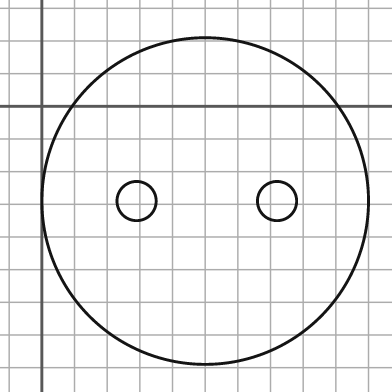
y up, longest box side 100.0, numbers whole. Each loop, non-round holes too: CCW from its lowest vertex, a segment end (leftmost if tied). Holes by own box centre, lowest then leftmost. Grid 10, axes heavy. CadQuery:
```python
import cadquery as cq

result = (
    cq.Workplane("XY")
    .moveTo(50.0, -29.0)
    .circle(50.0)
    .moveTo(29.0, -29.0)
    .circle(6.0)
    .moveTo(72.0, -29.0)
    .circle(6.0)
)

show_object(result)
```